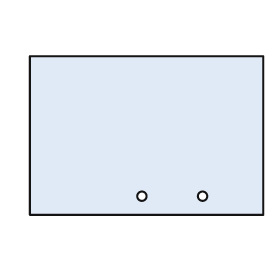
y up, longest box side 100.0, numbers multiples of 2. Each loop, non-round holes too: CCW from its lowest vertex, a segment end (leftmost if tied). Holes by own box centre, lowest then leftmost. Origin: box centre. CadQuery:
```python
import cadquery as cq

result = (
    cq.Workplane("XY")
    .moveTo(-50.0, -34.0)
    .lineTo(50.0, -34.0)
    .lineTo(50.0, 34.0)
    .lineTo(-50.0, 34.0)
    .close()
    .moveTo(-2.0, -26.0)
    .circle(2.0)
    .moveTo(24.0, -26.0)
    .circle(2.0)
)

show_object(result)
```